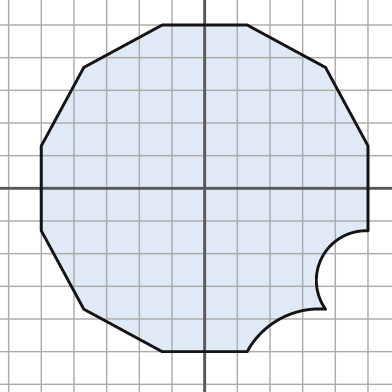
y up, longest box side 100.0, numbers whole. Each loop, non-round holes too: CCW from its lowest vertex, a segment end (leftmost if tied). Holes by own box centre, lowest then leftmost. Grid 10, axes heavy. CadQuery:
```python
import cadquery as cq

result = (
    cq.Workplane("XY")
    .moveTo(-13.0, -50.0)
    .lineTo(13.0, -50.0)
    .threePointArc((23.0, -40.0), (37.0, -37.0))
    .threePointArc((36.0, -21.0), (50.0, -13.0))
    .lineTo(50.0, 13.0)
    .lineTo(37.0, 37.0)
    .lineTo(13.0, 50.0)
    .lineTo(-13.0, 50.0)
    .lineTo(-37.0, 37.0)
    .lineTo(-50.0, 13.0)
    .lineTo(-50.0, -13.0)
    .lineTo(-37.0, -37.0)
    .close()
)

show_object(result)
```